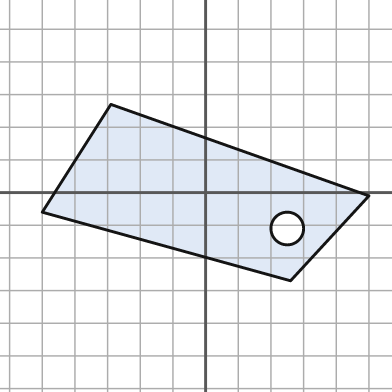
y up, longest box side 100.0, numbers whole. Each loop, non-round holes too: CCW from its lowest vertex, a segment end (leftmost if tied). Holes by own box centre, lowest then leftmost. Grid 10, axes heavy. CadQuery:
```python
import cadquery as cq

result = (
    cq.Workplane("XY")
    .moveTo(26.0, -27.0)
    .lineTo(50.0, -1.0)
    .lineTo(-29.0, 27.0)
    .lineTo(-50.0, -6.0)
    .close()
    .moveTo(25.0, -11.0)
    .circle(5.0)
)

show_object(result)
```